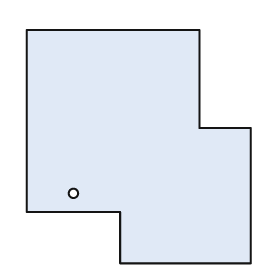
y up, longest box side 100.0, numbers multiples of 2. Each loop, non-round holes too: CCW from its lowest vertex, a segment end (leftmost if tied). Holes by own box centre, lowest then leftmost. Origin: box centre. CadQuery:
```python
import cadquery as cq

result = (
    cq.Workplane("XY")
    .moveTo(-8.0, -50.0)
    .lineTo(48.0, -50.0)
    .lineTo(48.0, 8.0)
    .lineTo(26.0, 8.0)
    .lineTo(26.0, 50.0)
    .lineTo(-48.0, 50.0)
    .lineTo(-48.0, -28.0)
    .lineTo(-8.0, -28.0)
    .close()
    .moveTo(-28.0, -20.0)
    .circle(2.0)
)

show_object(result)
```